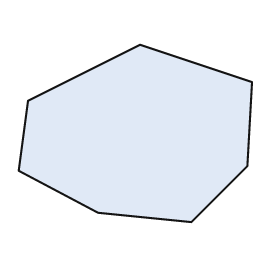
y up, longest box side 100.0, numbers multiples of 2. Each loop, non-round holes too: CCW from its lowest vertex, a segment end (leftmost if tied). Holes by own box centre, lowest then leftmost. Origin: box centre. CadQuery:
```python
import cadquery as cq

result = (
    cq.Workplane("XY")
    .moveTo(24.0, -38.0)
    .lineTo(48.0, -14.0)
    .lineTo(50.0, 22.0)
    .lineTo(2.0, 38.0)
    .lineTo(-46.0, 14.0)
    .lineTo(-50.0, -16.0)
    .lineTo(-16.0, -34.0)
    .close()
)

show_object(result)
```